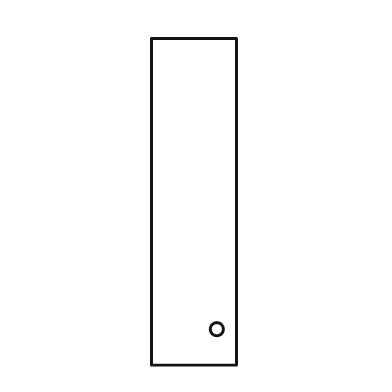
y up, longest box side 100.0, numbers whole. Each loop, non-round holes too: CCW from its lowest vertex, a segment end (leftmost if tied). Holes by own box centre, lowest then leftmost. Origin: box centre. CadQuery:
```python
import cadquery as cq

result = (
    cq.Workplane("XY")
    .moveTo(-13.0, -50.0)
    .lineTo(13.0, -50.0)
    .lineTo(13.0, 50.0)
    .lineTo(-13.0, 50.0)
    .close()
    .moveTo(7.0, -39.0)
    .circle(2.0)
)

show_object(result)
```